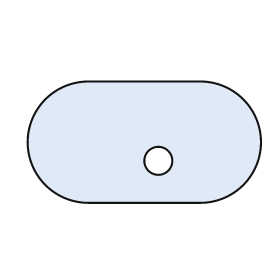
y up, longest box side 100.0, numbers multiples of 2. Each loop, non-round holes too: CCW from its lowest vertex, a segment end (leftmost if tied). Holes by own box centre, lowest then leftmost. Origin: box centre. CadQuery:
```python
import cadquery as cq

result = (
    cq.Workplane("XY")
    .moveTo(-24.0, -26.0)
    .lineTo(24.0, -26.0)
    .threePointArc((50.0, 0.0), (24.0, 26.0))
    .lineTo(-24.0, 26.0)
    .threePointArc((-50.0, 0.0), (-24.0, -26.0))
    .close()
    .moveTo(6.0, -8.0)
    .circle(6.0)
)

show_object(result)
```